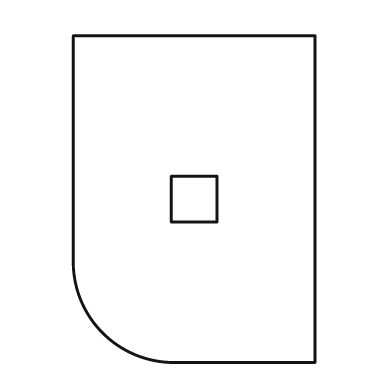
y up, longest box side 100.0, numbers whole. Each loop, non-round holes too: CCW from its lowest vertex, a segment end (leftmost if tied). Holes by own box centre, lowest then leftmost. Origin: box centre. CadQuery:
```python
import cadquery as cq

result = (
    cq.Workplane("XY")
    .moveTo(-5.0, -50.0)
    .lineTo(37.0, -50.0)
    .lineTo(37.0, 50.0)
    .lineTo(-37.0, 50.0)
    .lineTo(-37.0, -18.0)
    .threePointArc((-28.0, -41.0), (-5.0, -50.0))
    .close()
    .moveTo(-7.0, -7.0)
    .lineTo(7.0, -7.0)
    .lineTo(7.0, 7.0)
    .lineTo(-7.0, 7.0)
    .close()
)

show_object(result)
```